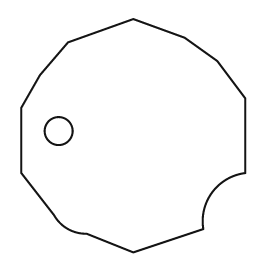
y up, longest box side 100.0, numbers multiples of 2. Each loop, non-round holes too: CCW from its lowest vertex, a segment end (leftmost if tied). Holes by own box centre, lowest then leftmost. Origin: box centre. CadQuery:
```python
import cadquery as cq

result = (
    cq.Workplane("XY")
    .moveTo(0.0, -50.0)
    .lineTo(30.0, -40.0)
    .threePointArc((34.0, -24.0), (48.0, -16.0))
    .lineTo(48.0, 16.0)
    .lineTo(36.0, 32.0)
    .lineTo(22.0, 42.0)
    .lineTo(0.0, 50.0)
    .lineTo(-28.0, 40.0)
    .lineTo(-40.0, 26.0)
    .lineTo(-48.0, 12.0)
    .lineTo(-48.0, -16.0)
    .lineTo(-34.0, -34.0)
    .threePointArc((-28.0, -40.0), (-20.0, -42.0))
    .close()
    .moveTo(-32.0, 2.0)
    .circle(6.0)
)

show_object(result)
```